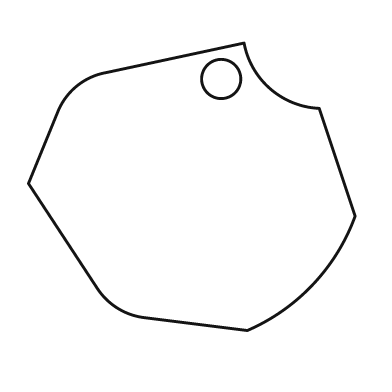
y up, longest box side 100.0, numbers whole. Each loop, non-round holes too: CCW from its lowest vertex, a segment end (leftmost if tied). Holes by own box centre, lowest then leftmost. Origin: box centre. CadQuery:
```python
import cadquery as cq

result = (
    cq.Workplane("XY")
    .moveTo(17.0, -44.0)
    .threePointArc((37.0, -30.0), (50.0, -9.0))
    .lineTo(39.0, 24.0)
    .threePointArc((24.0, 30.0), (16.0, 44.0))
    .lineTo(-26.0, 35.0)
    .threePointArc((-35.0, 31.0), (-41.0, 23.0))
    .lineTo(-50.0, 1.0)
    .lineTo(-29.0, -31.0)
    .threePointArc((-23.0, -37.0), (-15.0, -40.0))
    .close()
    .moveTo(9.0, 33.0)
    .circle(6.0)
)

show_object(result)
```